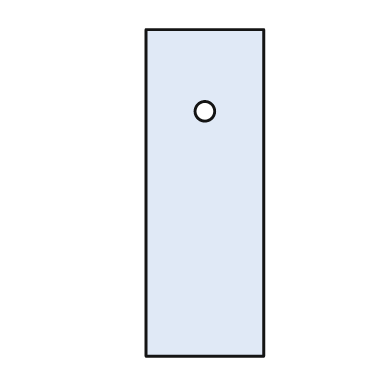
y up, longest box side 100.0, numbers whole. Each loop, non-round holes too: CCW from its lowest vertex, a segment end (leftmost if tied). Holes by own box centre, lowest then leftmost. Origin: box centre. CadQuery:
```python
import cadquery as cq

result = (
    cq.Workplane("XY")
    .moveTo(-18.0, -50.0)
    .lineTo(18.0, -50.0)
    .lineTo(18.0, 50.0)
    .lineTo(-18.0, 50.0)
    .close()
    .moveTo(0.0, 25.0)
    .circle(3.0)
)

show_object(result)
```